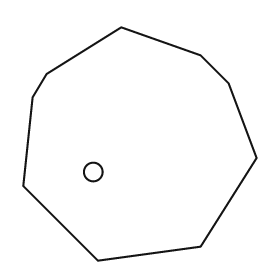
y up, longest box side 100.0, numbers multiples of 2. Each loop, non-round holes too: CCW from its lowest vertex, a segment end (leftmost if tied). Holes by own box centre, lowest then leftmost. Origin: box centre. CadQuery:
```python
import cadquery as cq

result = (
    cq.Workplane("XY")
    .moveTo(-18.0, -50.0)
    .lineTo(26.0, -44.0)
    .lineTo(50.0, -6.0)
    .lineTo(38.0, 26.0)
    .lineTo(26.0, 38.0)
    .lineTo(-8.0, 50.0)
    .lineTo(-40.0, 30.0)
    .lineTo(-46.0, 20.0)
    .lineTo(-50.0, -18.0)
    .close()
    .moveTo(-20.0, -12.0)
    .circle(4.0)
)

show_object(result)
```